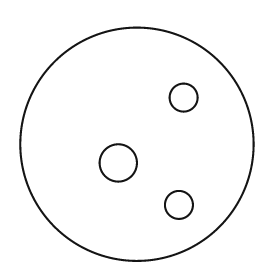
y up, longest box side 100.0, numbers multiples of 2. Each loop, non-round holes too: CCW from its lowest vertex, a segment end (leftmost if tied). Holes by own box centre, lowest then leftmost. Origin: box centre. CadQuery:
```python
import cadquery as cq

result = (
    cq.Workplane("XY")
    .moveTo(0.0, 0.0)
    .circle(50.0)
    .moveTo(18.0, -26.0)
    .circle(6.0)
    .moveTo(-8.0, -8.0)
    .circle(8.0)
    .moveTo(20.0, 20.0)
    .circle(6.0)
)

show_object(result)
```